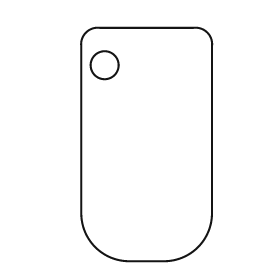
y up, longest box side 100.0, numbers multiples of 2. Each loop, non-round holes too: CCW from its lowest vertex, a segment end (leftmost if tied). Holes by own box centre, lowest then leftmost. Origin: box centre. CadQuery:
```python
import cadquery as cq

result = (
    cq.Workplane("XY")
    .moveTo(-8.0, -50.0)
    .lineTo(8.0, -50.0)
    .threePointArc((22.0, -44.0), (28.0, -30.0))
    .lineTo(28.0, 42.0)
    .threePointArc((26.0, 48.0), (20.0, 50.0))
    .lineTo(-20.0, 50.0)
    .threePointArc((-26.0, 48.0), (-28.0, 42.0))
    .lineTo(-28.0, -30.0)
    .threePointArc((-22.0, -44.0), (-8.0, -50.0))
    .close()
    .moveTo(-18.0, 34.0)
    .circle(6.0)
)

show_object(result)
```